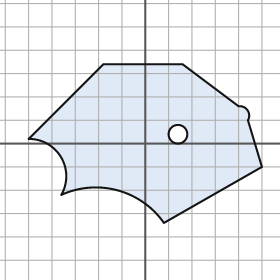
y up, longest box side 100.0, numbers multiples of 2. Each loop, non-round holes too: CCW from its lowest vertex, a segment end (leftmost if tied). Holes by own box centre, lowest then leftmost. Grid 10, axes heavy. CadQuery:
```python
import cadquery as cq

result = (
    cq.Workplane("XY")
    .moveTo(8.0, -34.0)
    .lineTo(50.0, -10.0)
    .lineTo(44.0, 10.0)
    .threePointArc((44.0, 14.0), (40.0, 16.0))
    .lineTo(16.0, 34.0)
    .lineTo(-18.0, 34.0)
    .lineTo(-50.0, 2.0)
    .threePointArc((-36.0, -6.0), (-36.0, -22.0))
    .threePointArc((-12.0, -20.0), (8.0, -34.0))
    .close()
    .moveTo(14.0, 4.0)
    .circle(4.0)
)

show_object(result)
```